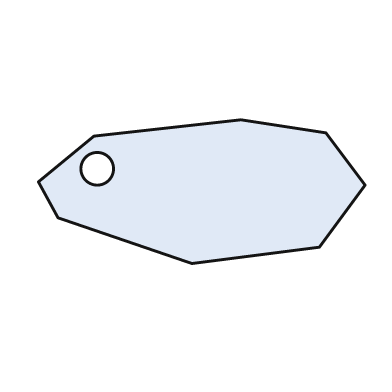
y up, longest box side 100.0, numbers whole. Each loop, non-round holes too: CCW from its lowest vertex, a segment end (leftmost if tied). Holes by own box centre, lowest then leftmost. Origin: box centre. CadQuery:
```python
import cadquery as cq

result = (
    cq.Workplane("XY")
    .moveTo(-3.0, -22.0)
    .lineTo(36.0, -17.0)
    .lineTo(50.0, 2.0)
    .lineTo(38.0, 18.0)
    .lineTo(12.0, 22.0)
    .lineTo(-33.0, 17.0)
    .lineTo(-50.0, 3.0)
    .lineTo(-44.0, -8.0)
    .close()
    .moveTo(-32.0, 7.0)
    .circle(5.0)
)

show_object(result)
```